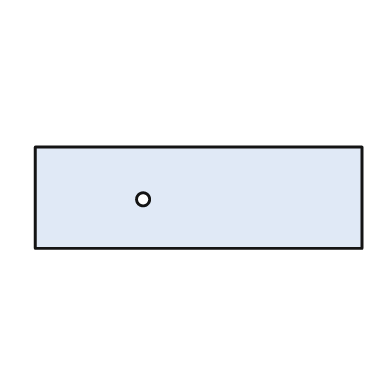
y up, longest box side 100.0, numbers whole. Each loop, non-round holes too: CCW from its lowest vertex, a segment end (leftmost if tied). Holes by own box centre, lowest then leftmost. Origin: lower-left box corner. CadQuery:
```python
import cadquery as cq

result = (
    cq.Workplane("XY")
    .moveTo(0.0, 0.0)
    .lineTo(100.0, 0.0)
    .lineTo(100.0, 31.0)
    .lineTo(0.0, 31.0)
    .close()
    .moveTo(33.0, 15.0)
    .circle(2.0)
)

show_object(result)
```